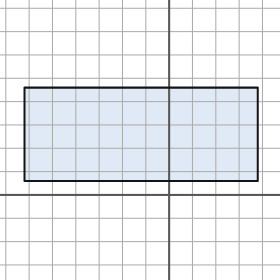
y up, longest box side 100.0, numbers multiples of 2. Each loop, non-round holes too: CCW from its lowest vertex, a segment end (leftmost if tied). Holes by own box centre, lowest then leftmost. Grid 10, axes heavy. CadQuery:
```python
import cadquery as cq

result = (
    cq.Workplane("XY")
    .moveTo(-62.0, 6.0)
    .lineTo(38.0, 6.0)
    .lineTo(38.0, 46.0)
    .lineTo(-62.0, 46.0)
    .close()
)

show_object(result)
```